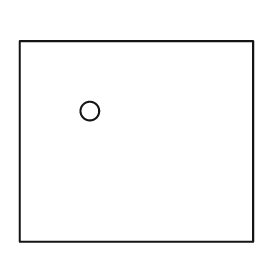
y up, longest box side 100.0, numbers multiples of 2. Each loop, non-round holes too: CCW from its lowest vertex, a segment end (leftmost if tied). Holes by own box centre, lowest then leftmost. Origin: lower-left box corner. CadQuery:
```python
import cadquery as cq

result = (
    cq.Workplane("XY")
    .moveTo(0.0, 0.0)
    .lineTo(100.0, 0.0)
    .lineTo(100.0, 86.0)
    .lineTo(0.0, 86.0)
    .close()
    .moveTo(30.0, 56.0)
    .circle(4.0)
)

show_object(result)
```